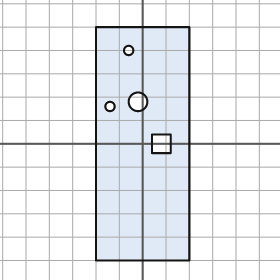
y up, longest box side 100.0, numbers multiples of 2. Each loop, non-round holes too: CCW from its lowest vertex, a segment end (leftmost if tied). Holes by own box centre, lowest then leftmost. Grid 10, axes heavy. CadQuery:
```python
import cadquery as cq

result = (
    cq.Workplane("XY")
    .moveTo(-20.0, -50.0)
    .lineTo(20.0, -50.0)
    .lineTo(20.0, 50.0)
    .lineTo(-20.0, 50.0)
    .close()
    .moveTo(4.0, -4.0)
    .lineTo(12.0, -4.0)
    .lineTo(12.0, 4.0)
    .lineTo(4.0, 4.0)
    .close()
    .moveTo(-14.0, 16.0)
    .circle(2.0)
    .moveTo(-2.0, 18.0)
    .circle(4.0)
    .moveTo(-6.0, 40.0)
    .circle(2.0)
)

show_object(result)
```